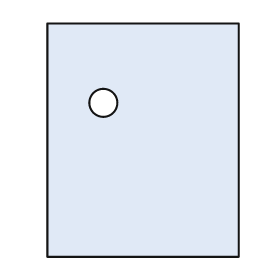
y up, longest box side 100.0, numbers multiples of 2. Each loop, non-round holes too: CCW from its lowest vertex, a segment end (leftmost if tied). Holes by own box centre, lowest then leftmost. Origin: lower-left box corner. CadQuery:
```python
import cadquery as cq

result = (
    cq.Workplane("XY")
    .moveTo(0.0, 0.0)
    .lineTo(82.0, 0.0)
    .lineTo(82.0, 100.0)
    .lineTo(0.0, 100.0)
    .close()
    .moveTo(24.0, 66.0)
    .circle(6.0)
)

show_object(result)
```